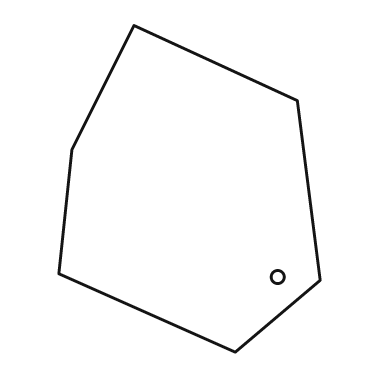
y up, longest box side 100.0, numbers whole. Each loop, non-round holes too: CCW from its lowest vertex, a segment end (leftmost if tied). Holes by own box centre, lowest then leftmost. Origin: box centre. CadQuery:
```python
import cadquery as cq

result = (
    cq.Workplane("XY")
    .moveTo(14.0, -50.0)
    .lineTo(40.0, -28.0)
    .lineTo(33.0, 27.0)
    .lineTo(-17.0, 50.0)
    .lineTo(-36.0, 12.0)
    .lineTo(-40.0, -26.0)
    .close()
    .moveTo(27.0, -27.0)
    .circle(2.0)
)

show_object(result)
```